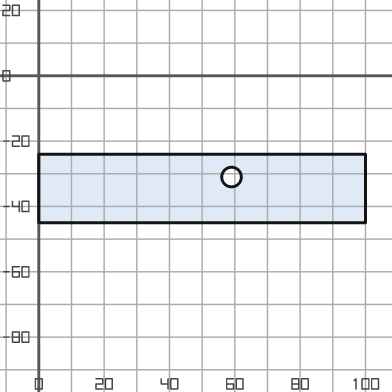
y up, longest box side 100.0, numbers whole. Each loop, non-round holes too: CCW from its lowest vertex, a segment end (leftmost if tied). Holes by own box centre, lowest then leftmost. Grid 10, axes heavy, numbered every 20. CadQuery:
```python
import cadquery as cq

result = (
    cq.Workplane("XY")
    .moveTo(0.0, -45.0)
    .lineTo(100.0, -45.0)
    .lineTo(100.0, -24.0)
    .lineTo(0.0, -24.0)
    .close()
    .moveTo(59.0, -31.0)
    .circle(3.0)
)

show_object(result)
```